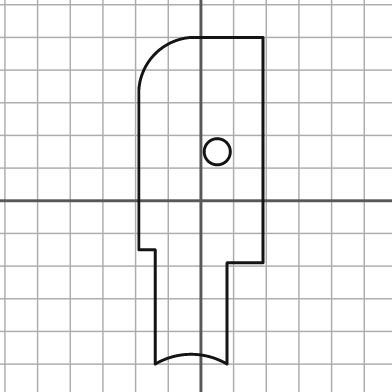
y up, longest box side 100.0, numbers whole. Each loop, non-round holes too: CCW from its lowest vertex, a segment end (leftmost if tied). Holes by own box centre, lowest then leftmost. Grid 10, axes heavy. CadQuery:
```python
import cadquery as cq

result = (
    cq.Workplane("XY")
    .moveTo(-14.0, -50.0)
    .threePointArc((-3.0, -47.0), (8.0, -50.0))
    .lineTo(8.0, -19.0)
    .lineTo(19.0, -19.0)
    .lineTo(19.0, 50.0)
    .lineTo(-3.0, 50.0)
    .threePointArc((-14.0, 45.0), (-19.0, 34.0))
    .lineTo(-19.0, -15.0)
    .lineTo(-14.0, -15.0)
    .close()
    .moveTo(5.0, 15.0)
    .circle(4.0)
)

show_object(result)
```